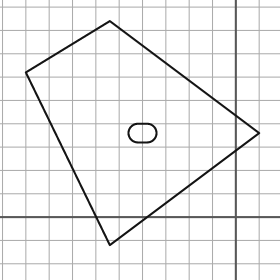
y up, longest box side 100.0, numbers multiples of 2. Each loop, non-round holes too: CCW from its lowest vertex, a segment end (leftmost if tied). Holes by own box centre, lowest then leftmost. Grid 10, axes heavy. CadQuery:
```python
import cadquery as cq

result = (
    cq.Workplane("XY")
    .moveTo(-54.0, -12.0)
    .lineTo(10.0, 36.0)
    .lineTo(-54.0, 84.0)
    .lineTo(-90.0, 62.0)
    .close()
    .moveTo(-42.0, 32.0)
    .lineTo(-38.0, 32.0)
    .threePointArc((-34.0, 36.0), (-38.0, 40.0))
    .lineTo(-42.0, 40.0)
    .threePointArc((-46.0, 36.0), (-42.0, 32.0))
    .close()
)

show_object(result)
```